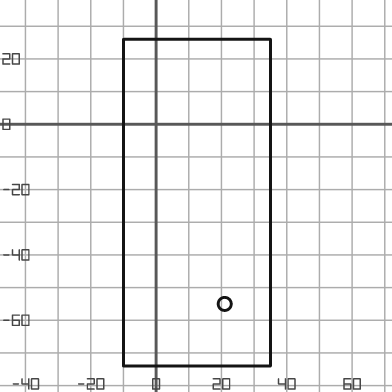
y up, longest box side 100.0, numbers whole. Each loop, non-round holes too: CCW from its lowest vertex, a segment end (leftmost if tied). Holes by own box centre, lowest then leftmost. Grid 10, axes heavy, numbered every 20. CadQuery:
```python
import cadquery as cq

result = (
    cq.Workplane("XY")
    .moveTo(-10.0, -74.0)
    .lineTo(35.0, -74.0)
    .lineTo(35.0, 26.0)
    .lineTo(-10.0, 26.0)
    .close()
    .moveTo(21.0, -55.0)
    .circle(2.0)
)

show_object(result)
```